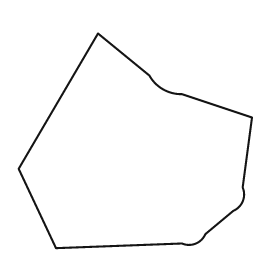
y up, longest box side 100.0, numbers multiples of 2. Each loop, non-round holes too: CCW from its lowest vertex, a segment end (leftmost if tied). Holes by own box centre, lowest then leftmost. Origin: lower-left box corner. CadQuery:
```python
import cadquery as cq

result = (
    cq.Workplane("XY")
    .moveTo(16.0, 0.0)
    .lineTo(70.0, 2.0)
    .threePointArc((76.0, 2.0), (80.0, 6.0))
    .lineTo(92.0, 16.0)
    .threePointArc((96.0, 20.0), (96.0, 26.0))
    .lineTo(100.0, 56.0)
    .lineTo(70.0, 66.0)
    .threePointArc((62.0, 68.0), (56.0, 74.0))
    .lineTo(34.0, 92.0)
    .lineTo(0.0, 34.0)
    .close()
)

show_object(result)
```